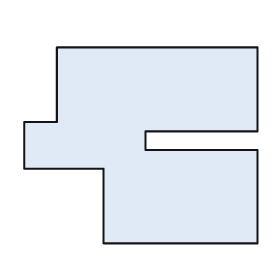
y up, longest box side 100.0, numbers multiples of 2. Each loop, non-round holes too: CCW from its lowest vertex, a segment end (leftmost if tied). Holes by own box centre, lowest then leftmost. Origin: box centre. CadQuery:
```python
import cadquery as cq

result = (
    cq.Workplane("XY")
    .moveTo(-16.0, -42.0)
    .lineTo(50.0, -42.0)
    .lineTo(50.0, -2.0)
    .lineTo(2.0, -2.0)
    .lineTo(2.0, 6.0)
    .lineTo(50.0, 6.0)
    .lineTo(50.0, 42.0)
    .lineTo(-36.0, 42.0)
    .lineTo(-36.0, 10.0)
    .lineTo(-50.0, 10.0)
    .lineTo(-50.0, -10.0)
    .lineTo(-16.0, -10.0)
    .close()
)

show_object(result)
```